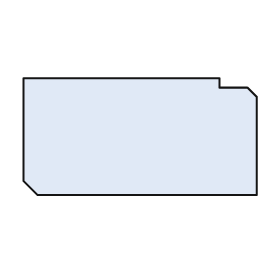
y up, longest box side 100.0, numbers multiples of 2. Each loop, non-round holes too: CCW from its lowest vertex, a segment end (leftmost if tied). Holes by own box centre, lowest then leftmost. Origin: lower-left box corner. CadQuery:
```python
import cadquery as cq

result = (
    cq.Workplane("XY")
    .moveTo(6.0, 0.0)
    .lineTo(100.0, 0.0)
    .lineTo(100.0, 42.0)
    .lineTo(96.0, 46.0)
    .lineTo(84.0, 46.0)
    .lineTo(84.0, 50.0)
    .lineTo(0.0, 50.0)
    .lineTo(0.0, 6.0)
    .close()
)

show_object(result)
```